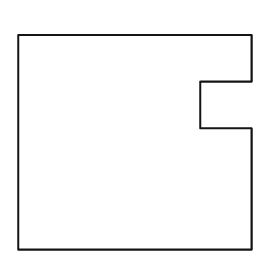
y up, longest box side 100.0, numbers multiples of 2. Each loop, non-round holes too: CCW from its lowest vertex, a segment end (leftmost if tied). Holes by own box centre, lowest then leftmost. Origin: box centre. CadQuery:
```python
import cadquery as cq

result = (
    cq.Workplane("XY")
    .moveTo(-50.0, -46.0)
    .lineTo(50.0, -46.0)
    .lineTo(50.0, 6.0)
    .lineTo(28.0, 6.0)
    .lineTo(28.0, 26.0)
    .lineTo(50.0, 26.0)
    .lineTo(50.0, 46.0)
    .lineTo(-50.0, 46.0)
    .close()
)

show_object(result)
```